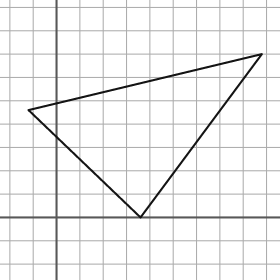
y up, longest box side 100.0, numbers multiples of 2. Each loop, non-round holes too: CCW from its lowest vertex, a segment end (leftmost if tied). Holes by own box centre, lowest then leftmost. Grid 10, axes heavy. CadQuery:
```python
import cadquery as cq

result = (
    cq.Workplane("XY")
    .moveTo(36.0, 0.0)
    .lineTo(88.0, 70.0)
    .lineTo(-12.0, 46.0)
    .close()
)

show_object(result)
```